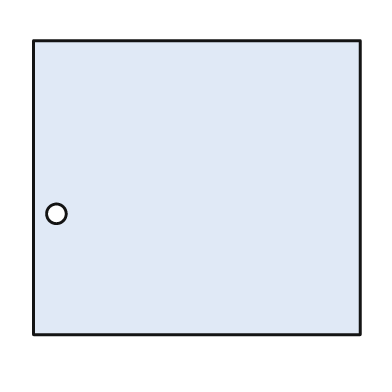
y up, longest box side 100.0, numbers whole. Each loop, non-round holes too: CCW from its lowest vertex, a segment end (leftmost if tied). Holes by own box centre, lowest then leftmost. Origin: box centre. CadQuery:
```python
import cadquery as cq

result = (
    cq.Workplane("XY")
    .moveTo(-50.0, -45.0)
    .lineTo(50.0, -45.0)
    .lineTo(50.0, 45.0)
    .lineTo(-50.0, 45.0)
    .close()
    .moveTo(-43.0, -8.0)
    .circle(3.0)
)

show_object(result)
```